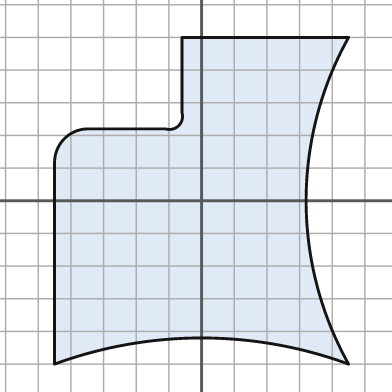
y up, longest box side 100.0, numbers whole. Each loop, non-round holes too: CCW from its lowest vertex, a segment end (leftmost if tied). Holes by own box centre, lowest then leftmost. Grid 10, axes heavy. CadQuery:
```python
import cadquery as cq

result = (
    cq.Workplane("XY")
    .moveTo(-45.0, -50.0)
    .threePointArc((0.0, -42.0), (45.0, -50.0))
    .threePointArc((32.0, 0.0), (45.0, 50.0))
    .lineTo(-6.0, 50.0)
    .lineTo(-6.0, 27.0)
    .threePointArc((-7.0, 23.0), (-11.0, 22.0))
    .lineTo(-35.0, 22.0)
    .threePointArc((-42.0, 19.0), (-45.0, 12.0))
    .close()
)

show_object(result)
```